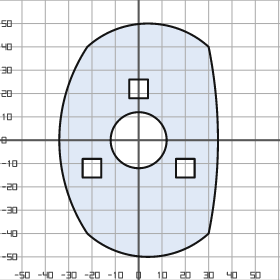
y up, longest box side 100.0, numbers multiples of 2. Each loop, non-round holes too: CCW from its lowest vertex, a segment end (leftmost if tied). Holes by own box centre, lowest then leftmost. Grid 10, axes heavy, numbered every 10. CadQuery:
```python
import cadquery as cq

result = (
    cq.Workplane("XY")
    .moveTo(-22.0, -40.0)
    .threePointArc((4.0, -50.0), (30.0, -40.0))
    .threePointArc((34.0, 0.0), (30.0, 40.0))
    .threePointArc((4.0, 50.0), (-22.0, 40.0))
    .threePointArc((-34.0, 0.0), (-22.0, -40.0))
    .close()
    .moveTo(-24.0, -16.0)
    .lineTo(-16.0, -16.0)
    .lineTo(-16.0, -8.0)
    .lineTo(-24.0, -8.0)
    .close()
    .moveTo(16.0, -16.0)
    .lineTo(24.0, -16.0)
    .lineTo(24.0, -8.0)
    .lineTo(16.0, -8.0)
    .close()
    .moveTo(0.0, 0.0)
    .circle(12.0)
    .moveTo(-4.0, 18.0)
    .lineTo(4.0, 18.0)
    .lineTo(4.0, 26.0)
    .lineTo(-4.0, 26.0)
    .close()
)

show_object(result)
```